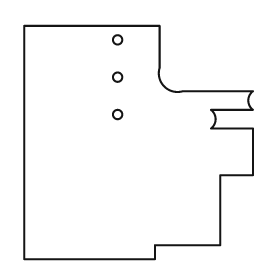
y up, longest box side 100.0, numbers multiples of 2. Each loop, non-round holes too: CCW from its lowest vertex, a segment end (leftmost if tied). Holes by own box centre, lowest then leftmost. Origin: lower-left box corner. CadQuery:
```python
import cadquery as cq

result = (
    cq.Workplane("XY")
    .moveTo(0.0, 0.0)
    .lineTo(56.0, 0.0)
    .lineTo(56.0, 6.0)
    .lineTo(84.0, 6.0)
    .lineTo(84.0, 36.0)
    .lineTo(98.0, 36.0)
    .lineTo(98.0, 56.0)
    .lineTo(80.0, 56.0)
    .threePointArc((82.0, 60.0), (80.0, 64.0))
    .lineTo(98.0, 64.0)
    .threePointArc((96.0, 68.0), (98.0, 72.0))
    .lineTo(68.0, 72.0)
    .threePointArc((60.0, 74.0), (58.0, 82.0))
    .lineTo(58.0, 100.0)
    .lineTo(0.0, 100.0)
    .close()
    .moveTo(40.0, 62.0)
    .circle(2.0)
    .moveTo(40.0, 78.0)
    .circle(2.0)
    .moveTo(40.0, 94.0)
    .circle(2.0)
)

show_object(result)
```